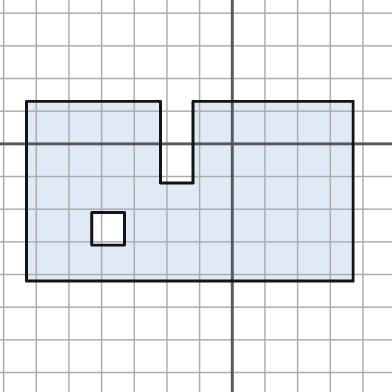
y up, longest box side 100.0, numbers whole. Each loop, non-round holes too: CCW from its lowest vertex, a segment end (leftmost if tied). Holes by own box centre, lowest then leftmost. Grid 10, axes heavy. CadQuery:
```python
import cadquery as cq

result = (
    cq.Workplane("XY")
    .moveTo(-63.0, -42.0)
    .lineTo(37.0, -42.0)
    .lineTo(37.0, 13.0)
    .lineTo(-12.0, 13.0)
    .lineTo(-12.0, -12.0)
    .lineTo(-22.0, -12.0)
    .lineTo(-22.0, 13.0)
    .lineTo(-63.0, 13.0)
    .close()
    .moveTo(-43.0, -31.0)
    .lineTo(-33.0, -31.0)
    .lineTo(-33.0, -21.0)
    .lineTo(-43.0, -21.0)
    .close()
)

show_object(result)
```